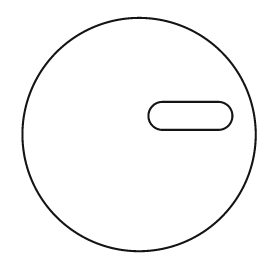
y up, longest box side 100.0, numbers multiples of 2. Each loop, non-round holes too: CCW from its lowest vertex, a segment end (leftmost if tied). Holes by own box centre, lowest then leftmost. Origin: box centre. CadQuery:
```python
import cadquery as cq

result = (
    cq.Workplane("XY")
    .moveTo(0.0, 0.0)
    .circle(50.0)
    .moveTo(10.0, 2.0)
    .lineTo(34.0, 2.0)
    .threePointArc((40.0, 8.0), (34.0, 14.0))
    .lineTo(10.0, 14.0)
    .threePointArc((4.0, 8.0), (10.0, 2.0))
    .close()
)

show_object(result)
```